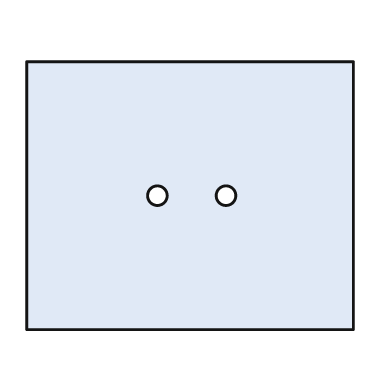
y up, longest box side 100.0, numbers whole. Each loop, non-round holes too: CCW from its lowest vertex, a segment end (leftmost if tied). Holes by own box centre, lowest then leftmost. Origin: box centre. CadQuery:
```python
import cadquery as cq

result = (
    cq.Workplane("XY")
    .moveTo(-50.0, -41.0)
    .lineTo(50.0, -41.0)
    .lineTo(50.0, 41.0)
    .lineTo(-50.0, 41.0)
    .close()
    .moveTo(-10.0, 0.0)
    .circle(3.0)
    .moveTo(11.0, 0.0)
    .circle(3.0)
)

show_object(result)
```